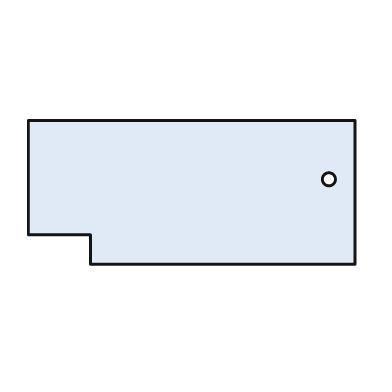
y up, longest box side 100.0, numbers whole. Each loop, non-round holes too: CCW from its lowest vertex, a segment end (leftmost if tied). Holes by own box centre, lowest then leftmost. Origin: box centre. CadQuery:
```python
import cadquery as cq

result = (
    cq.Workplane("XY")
    .moveTo(-31.0, -22.0)
    .lineTo(50.0, -22.0)
    .lineTo(50.0, 22.0)
    .lineTo(-50.0, 22.0)
    .lineTo(-50.0, -13.0)
    .lineTo(-31.0, -13.0)
    .close()
    .moveTo(42.0, 4.0)
    .circle(2.0)
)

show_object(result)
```